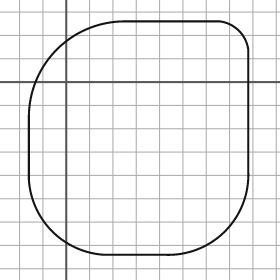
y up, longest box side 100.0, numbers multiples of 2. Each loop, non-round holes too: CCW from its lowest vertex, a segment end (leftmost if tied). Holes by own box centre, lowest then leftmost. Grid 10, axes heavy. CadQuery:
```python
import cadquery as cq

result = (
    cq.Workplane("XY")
    .moveTo(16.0, -74.0)
    .lineTo(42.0, -74.0)
    .threePointArc((68.0, -64.0), (78.0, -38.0))
    .lineTo(78.0, 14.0)
    .threePointArc((74.0, 22.0), (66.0, 26.0))
    .lineTo(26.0, 26.0)
    .threePointArc((-4.0, 14.0), (-16.0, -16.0))
    .lineTo(-16.0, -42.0)
    .threePointArc((-6.0, -64.0), (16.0, -74.0))
    .close()
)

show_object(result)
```